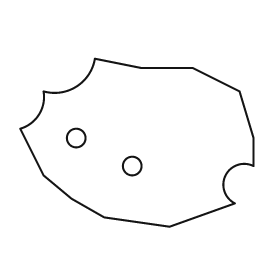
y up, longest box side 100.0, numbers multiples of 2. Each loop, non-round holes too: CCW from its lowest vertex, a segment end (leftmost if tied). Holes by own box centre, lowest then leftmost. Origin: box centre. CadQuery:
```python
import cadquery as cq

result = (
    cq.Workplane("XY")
    .moveTo(14.0, -36.0)
    .lineTo(42.0, -26.0)
    .threePointArc((38.0, -14.0), (50.0, -10.0))
    .lineTo(50.0, 2.0)
    .lineTo(44.0, 22.0)
    .lineTo(24.0, 32.0)
    .lineTo(2.0, 32.0)
    .lineTo(-18.0, 36.0)
    .threePointArc((-26.0, 24.0), (-40.0, 22.0))
    .threePointArc((-42.0, 12.0), (-50.0, 6.0))
    .lineTo(-40.0, -14.0)
    .lineTo(-28.0, -24.0)
    .lineTo(-14.0, -32.0)
    .close()
    .moveTo(-2.0, -10.0)
    .circle(4.0)
    .moveTo(-26.0, 2.0)
    .circle(4.0)
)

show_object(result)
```